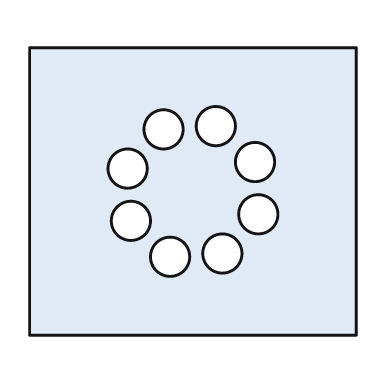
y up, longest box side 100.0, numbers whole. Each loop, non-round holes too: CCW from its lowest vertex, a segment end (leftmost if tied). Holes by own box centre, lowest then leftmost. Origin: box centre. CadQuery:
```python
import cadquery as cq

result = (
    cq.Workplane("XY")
    .moveTo(-50.0, -44.0)
    .lineTo(50.0, -44.0)
    .lineTo(50.0, 44.0)
    .lineTo(-50.0, 44.0)
    .close()
    .moveTo(-7.0, -20.0)
    .circle(6.0)
    .moveTo(9.0, -19.0)
    .circle(6.0)
    .moveTo(-19.0, -9.0)
    .circle(6.0)
    .moveTo(20.0, -7.0)
    .circle(6.0)
    .moveTo(-20.0, 7.0)
    .circle(6.0)
    .moveTo(19.0, 9.0)
    .circle(6.0)
    .moveTo(-9.0, 19.0)
    .circle(6.0)
    .moveTo(7.0, 20.0)
    .circle(6.0)
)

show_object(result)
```